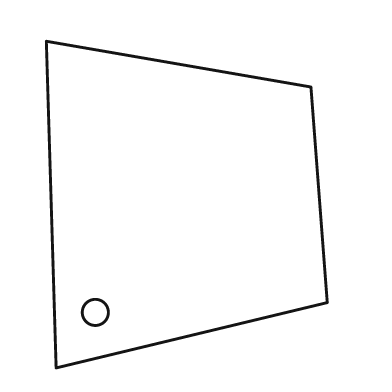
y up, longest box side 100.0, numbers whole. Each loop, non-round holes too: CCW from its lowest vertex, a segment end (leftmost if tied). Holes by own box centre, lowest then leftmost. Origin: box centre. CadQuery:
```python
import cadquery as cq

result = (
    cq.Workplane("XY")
    .moveTo(-40.0, -50.0)
    .lineTo(43.0, -30.0)
    .lineTo(38.0, 36.0)
    .lineTo(-43.0, 50.0)
    .close()
    .moveTo(-28.0, -33.0)
    .circle(4.0)
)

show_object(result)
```